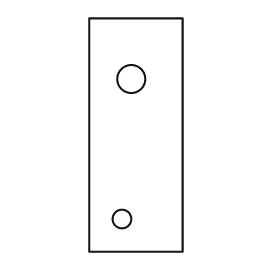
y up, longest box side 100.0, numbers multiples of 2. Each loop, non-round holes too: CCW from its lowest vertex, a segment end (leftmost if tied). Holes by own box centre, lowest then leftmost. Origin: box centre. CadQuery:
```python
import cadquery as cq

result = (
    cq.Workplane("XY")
    .moveTo(-20.0, -50.0)
    .lineTo(20.0, -50.0)
    .lineTo(20.0, 50.0)
    .lineTo(-20.0, 50.0)
    .close()
    .moveTo(-6.0, -36.0)
    .circle(4.0)
    .moveTo(-2.0, 24.0)
    .circle(6.0)
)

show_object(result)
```